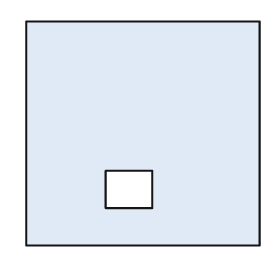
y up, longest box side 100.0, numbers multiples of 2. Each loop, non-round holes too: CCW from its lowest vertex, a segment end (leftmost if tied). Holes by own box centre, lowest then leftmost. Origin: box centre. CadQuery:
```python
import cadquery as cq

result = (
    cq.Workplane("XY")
    .moveTo(-50.0, -48.0)
    .lineTo(50.0, -48.0)
    .lineTo(50.0, 48.0)
    .lineTo(-50.0, 48.0)
    .close()
    .moveTo(-16.0, -32.0)
    .lineTo(4.0, -32.0)
    .lineTo(4.0, -16.0)
    .lineTo(-16.0, -16.0)
    .close()
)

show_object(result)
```